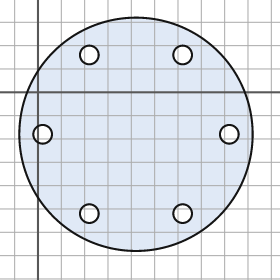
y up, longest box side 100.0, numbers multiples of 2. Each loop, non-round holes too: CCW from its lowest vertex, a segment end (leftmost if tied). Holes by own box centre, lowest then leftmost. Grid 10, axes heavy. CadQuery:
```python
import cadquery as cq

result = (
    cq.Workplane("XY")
    .moveTo(42.0, -18.0)
    .circle(50.0)
    .moveTo(22.0, -52.0)
    .circle(4.0)
    .moveTo(62.0, -52.0)
    .circle(4.0)
    .moveTo(2.0, -18.0)
    .circle(4.0)
    .moveTo(82.0, -18.0)
    .circle(4.0)
    .moveTo(22.0, 16.0)
    .circle(4.0)
    .moveTo(62.0, 16.0)
    .circle(4.0)
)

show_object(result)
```